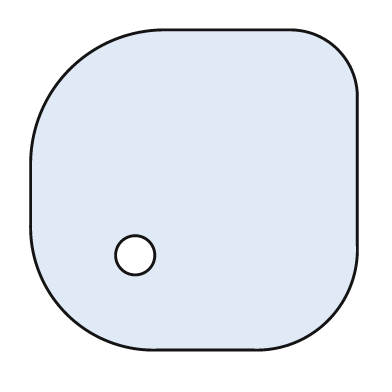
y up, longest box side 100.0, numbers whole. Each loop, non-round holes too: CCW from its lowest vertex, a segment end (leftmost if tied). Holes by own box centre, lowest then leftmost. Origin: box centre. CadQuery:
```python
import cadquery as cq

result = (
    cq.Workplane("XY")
    .moveTo(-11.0, -49.0)
    .lineTo(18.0, -49.0)
    .threePointArc((41.0, -40.0), (50.0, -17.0))
    .lineTo(50.0, 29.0)
    .threePointArc((44.0, 43.0), (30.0, 49.0))
    .lineTo(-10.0, 49.0)
    .threePointArc((-38.0, 37.0), (-50.0, 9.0))
    .lineTo(-50.0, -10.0)
    .threePointArc((-39.0, -38.0), (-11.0, -49.0))
    .close()
    .moveTo(-18.0, -20.0)
    .circle(6.0)
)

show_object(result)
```